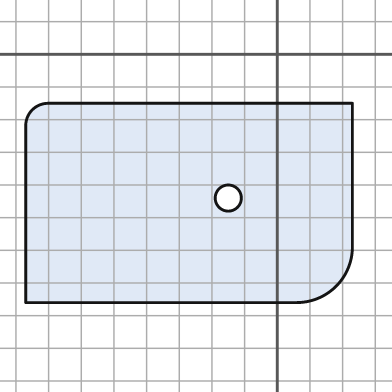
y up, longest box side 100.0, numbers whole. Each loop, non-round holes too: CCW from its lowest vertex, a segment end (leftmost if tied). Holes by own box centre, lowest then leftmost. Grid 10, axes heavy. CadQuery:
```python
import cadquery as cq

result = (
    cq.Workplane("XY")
    .moveTo(-77.0, -76.0)
    .lineTo(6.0, -76.0)
    .threePointArc((18.0, -71.0), (23.0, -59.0))
    .lineTo(23.0, -15.0)
    .lineTo(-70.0, -15.0)
    .threePointArc((-75.0, -17.0), (-77.0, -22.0))
    .close()
    .moveTo(-15.0, -44.0)
    .circle(4.0)
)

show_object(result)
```